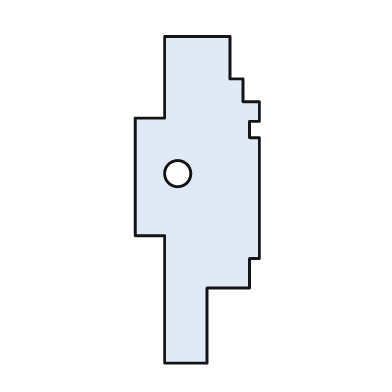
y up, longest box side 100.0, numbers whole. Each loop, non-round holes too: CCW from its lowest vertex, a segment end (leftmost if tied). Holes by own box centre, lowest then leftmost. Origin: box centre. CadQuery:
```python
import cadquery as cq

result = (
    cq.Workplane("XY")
    .moveTo(-10.0, -50.0)
    .lineTo(3.0, -50.0)
    .lineTo(3.0, -27.0)
    .lineTo(16.0, -27.0)
    .lineTo(16.0, -18.0)
    .lineTo(19.0, -18.0)
    .lineTo(19.0, 19.0)
    .lineTo(16.0, 19.0)
    .lineTo(16.0, 24.0)
    .lineTo(19.0, 24.0)
    .lineTo(19.0, 30.0)
    .lineTo(14.0, 30.0)
    .lineTo(14.0, 37.0)
    .lineTo(10.0, 37.0)
    .lineTo(10.0, 50.0)
    .lineTo(-10.0, 50.0)
    .lineTo(-10.0, 25.0)
    .lineTo(-19.0, 25.0)
    .lineTo(-19.0, -11.0)
    .lineTo(-10.0, -11.0)
    .close()
    .moveTo(-6.0, 8.0)
    .circle(4.0)
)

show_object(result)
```